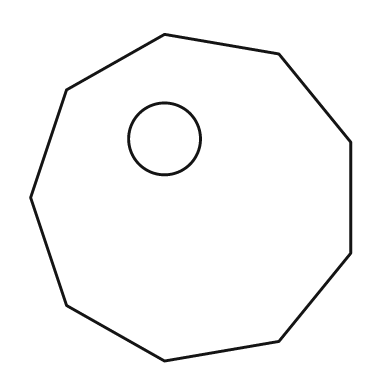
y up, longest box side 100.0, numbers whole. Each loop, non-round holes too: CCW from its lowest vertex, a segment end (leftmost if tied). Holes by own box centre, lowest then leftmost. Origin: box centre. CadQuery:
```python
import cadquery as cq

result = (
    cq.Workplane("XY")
    .moveTo(-8.0, -50.0)
    .lineTo(27.0, -44.0)
    .lineTo(49.0, -17.0)
    .lineTo(49.0, 17.0)
    .lineTo(27.0, 44.0)
    .lineTo(-8.0, 50.0)
    .lineTo(-38.0, 33.0)
    .lineTo(-49.0, 0.0)
    .lineTo(-38.0, -33.0)
    .close()
    .moveTo(-8.0, 18.0)
    .circle(11.0)
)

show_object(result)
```